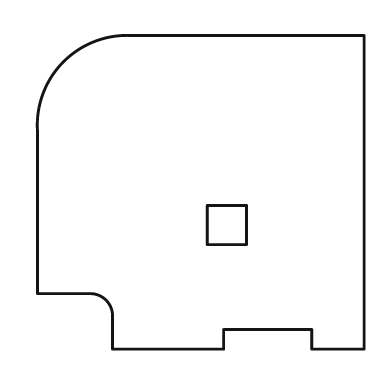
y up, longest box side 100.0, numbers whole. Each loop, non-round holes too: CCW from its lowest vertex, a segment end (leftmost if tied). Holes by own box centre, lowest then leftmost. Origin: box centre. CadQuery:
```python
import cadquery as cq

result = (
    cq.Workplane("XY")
    .moveTo(-27.0, -48.0)
    .lineTo(7.0, -48.0)
    .lineTo(7.0, -42.0)
    .lineTo(34.0, -42.0)
    .lineTo(34.0, -48.0)
    .lineTo(50.0, -48.0)
    .lineTo(50.0, 48.0)
    .lineTo(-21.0, 48.0)
    .threePointArc((-42.0, 40.0), (-50.0, 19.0))
    .lineTo(-50.0, -31.0)
    .lineTo(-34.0, -31.0)
    .threePointArc((-29.0, -33.0), (-27.0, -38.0))
    .close()
    .moveTo(2.0, -16.0)
    .lineTo(14.0, -16.0)
    .lineTo(14.0, -4.0)
    .lineTo(2.0, -4.0)
    .close()
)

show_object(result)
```